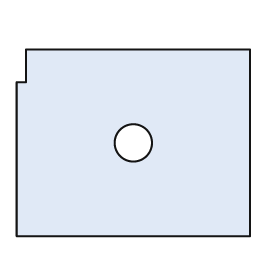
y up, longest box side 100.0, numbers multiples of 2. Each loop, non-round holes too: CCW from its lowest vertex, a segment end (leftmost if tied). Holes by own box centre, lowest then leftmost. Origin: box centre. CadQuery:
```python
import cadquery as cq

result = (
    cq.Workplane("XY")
    .moveTo(-50.0, -40.0)
    .lineTo(50.0, -40.0)
    .lineTo(50.0, 40.0)
    .lineTo(-46.0, 40.0)
    .lineTo(-46.0, 26.0)
    .lineTo(-50.0, 26.0)
    .close()
    .moveTo(0.0, 0.0)
    .circle(8.0)
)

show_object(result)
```